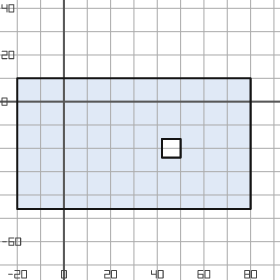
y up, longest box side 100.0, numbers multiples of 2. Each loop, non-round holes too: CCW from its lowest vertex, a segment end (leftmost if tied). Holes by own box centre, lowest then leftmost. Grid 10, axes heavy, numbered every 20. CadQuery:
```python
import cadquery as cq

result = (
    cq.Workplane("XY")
    .moveTo(-20.0, -46.0)
    .lineTo(80.0, -46.0)
    .lineTo(80.0, 10.0)
    .lineTo(-20.0, 10.0)
    .close()
    .moveTo(42.0, -24.0)
    .lineTo(50.0, -24.0)
    .lineTo(50.0, -16.0)
    .lineTo(42.0, -16.0)
    .close()
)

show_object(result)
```